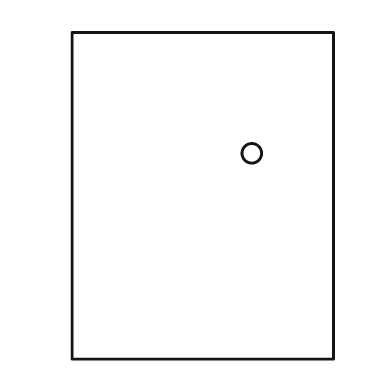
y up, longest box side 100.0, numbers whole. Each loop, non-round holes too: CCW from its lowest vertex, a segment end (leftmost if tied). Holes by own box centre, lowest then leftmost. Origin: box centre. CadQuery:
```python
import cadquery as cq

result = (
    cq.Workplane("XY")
    .moveTo(-40.0, -50.0)
    .lineTo(40.0, -50.0)
    .lineTo(40.0, 50.0)
    .lineTo(-40.0, 50.0)
    .close()
    .moveTo(15.0, 13.0)
    .circle(3.0)
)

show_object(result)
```